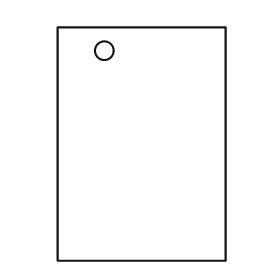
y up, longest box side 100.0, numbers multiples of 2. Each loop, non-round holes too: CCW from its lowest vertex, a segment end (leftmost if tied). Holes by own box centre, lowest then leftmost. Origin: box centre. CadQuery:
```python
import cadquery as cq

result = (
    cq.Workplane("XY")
    .moveTo(-36.0, -50.0)
    .lineTo(36.0, -50.0)
    .lineTo(36.0, 50.0)
    .lineTo(-36.0, 50.0)
    .close()
    .moveTo(-16.0, 40.0)
    .circle(4.0)
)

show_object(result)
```